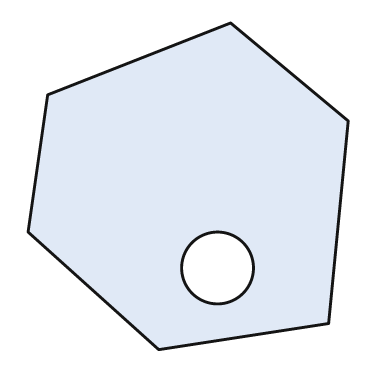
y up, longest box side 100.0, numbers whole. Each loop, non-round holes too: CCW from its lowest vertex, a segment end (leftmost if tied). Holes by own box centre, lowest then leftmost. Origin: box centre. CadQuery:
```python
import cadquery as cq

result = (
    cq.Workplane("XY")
    .moveTo(-9.0, -50.0)
    .lineTo(43.0, -42.0)
    .lineTo(49.0, 20.0)
    .lineTo(13.0, 50.0)
    .lineTo(-43.0, 28.0)
    .lineTo(-49.0, -14.0)
    .close()
    .moveTo(9.0, -25.0)
    .circle(11.0)
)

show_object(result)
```